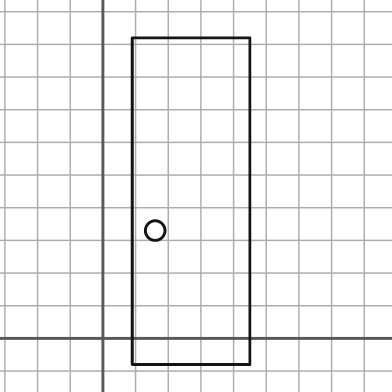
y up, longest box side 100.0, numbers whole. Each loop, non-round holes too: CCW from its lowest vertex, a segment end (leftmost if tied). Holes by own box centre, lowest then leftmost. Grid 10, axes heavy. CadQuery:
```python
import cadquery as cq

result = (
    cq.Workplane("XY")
    .moveTo(9.0, -8.0)
    .lineTo(45.0, -8.0)
    .lineTo(45.0, 92.0)
    .lineTo(9.0, 92.0)
    .close()
    .moveTo(16.0, 33.0)
    .circle(3.0)
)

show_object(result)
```